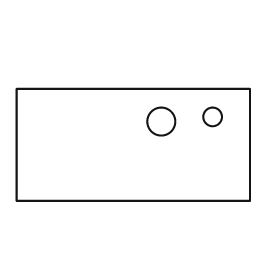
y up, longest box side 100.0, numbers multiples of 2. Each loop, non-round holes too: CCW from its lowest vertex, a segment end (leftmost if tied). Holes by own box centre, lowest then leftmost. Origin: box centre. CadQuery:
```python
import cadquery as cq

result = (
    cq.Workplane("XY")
    .moveTo(-50.0, -24.0)
    .lineTo(50.0, -24.0)
    .lineTo(50.0, 24.0)
    .lineTo(-50.0, 24.0)
    .close()
    .moveTo(12.0, 10.0)
    .circle(6.0)
    .moveTo(34.0, 12.0)
    .circle(4.0)
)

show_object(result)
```